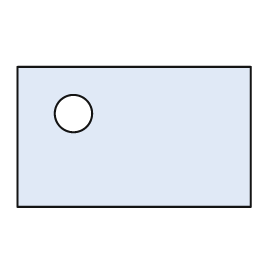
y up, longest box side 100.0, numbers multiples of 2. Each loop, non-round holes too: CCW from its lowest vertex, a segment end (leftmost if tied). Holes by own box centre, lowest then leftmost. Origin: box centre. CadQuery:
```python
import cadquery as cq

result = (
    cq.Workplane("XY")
    .moveTo(-50.0, -30.0)
    .lineTo(50.0, -30.0)
    .lineTo(50.0, 30.0)
    .lineTo(-50.0, 30.0)
    .close()
    .moveTo(-26.0, 10.0)
    .circle(8.0)
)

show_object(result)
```